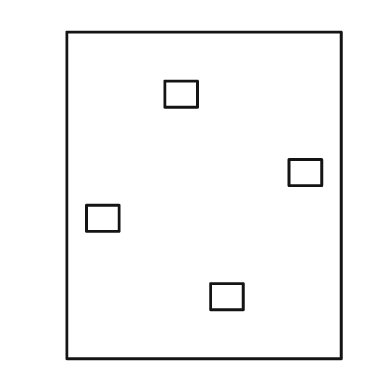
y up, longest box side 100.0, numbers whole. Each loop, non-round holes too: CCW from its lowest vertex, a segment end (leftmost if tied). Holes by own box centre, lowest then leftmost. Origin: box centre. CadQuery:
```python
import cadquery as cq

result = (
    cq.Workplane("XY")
    .moveTo(-42.0, -50.0)
    .lineTo(42.0, -50.0)
    .lineTo(42.0, 50.0)
    .lineTo(-42.0, 50.0)
    .close()
    .moveTo(2.0, -35.0)
    .lineTo(12.0, -35.0)
    .lineTo(12.0, -27.0)
    .lineTo(2.0, -27.0)
    .close()
    .moveTo(-36.0, -11.0)
    .lineTo(-26.0, -11.0)
    .lineTo(-26.0, -3.0)
    .lineTo(-36.0, -3.0)
    .close()
    .moveTo(26.0, 3.0)
    .lineTo(36.0, 3.0)
    .lineTo(36.0, 11.0)
    .lineTo(26.0, 11.0)
    .close()
    .moveTo(-12.0, 27.0)
    .lineTo(-2.0, 27.0)
    .lineTo(-2.0, 35.0)
    .lineTo(-12.0, 35.0)
    .close()
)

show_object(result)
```